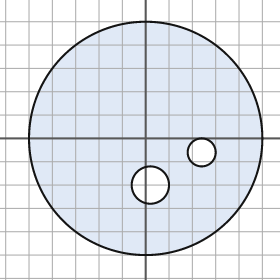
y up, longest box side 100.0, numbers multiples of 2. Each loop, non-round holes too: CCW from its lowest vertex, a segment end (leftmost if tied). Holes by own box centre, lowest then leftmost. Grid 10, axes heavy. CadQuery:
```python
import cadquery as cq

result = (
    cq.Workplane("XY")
    .moveTo(0.0, 0.0)
    .circle(50.0)
    .moveTo(2.0, -20.0)
    .circle(8.0)
    .moveTo(24.0, -6.0)
    .circle(6.0)
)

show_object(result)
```